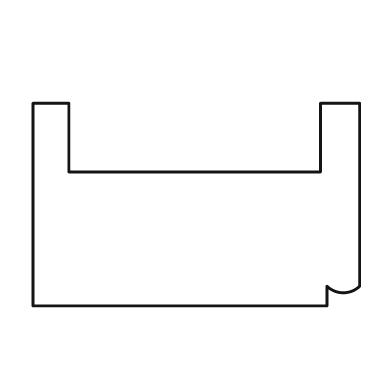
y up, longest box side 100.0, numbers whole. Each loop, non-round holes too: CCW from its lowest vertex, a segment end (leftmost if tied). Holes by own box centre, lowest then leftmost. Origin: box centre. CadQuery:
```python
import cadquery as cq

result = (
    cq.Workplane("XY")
    .moveTo(-50.0, -31.0)
    .lineTo(40.0, -31.0)
    .lineTo(40.0, -25.0)
    .threePointArc((45.0, -27.0), (50.0, -25.0))
    .lineTo(50.0, 31.0)
    .lineTo(38.0, 31.0)
    .lineTo(38.0, 10.0)
    .lineTo(-39.0, 10.0)
    .lineTo(-39.0, 31.0)
    .lineTo(-50.0, 31.0)
    .close()
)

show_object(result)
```